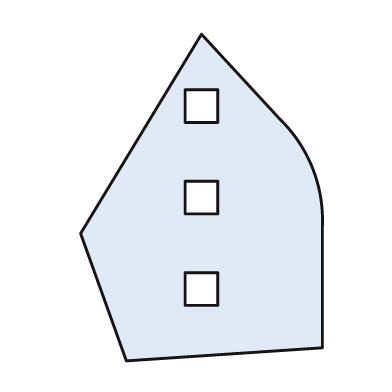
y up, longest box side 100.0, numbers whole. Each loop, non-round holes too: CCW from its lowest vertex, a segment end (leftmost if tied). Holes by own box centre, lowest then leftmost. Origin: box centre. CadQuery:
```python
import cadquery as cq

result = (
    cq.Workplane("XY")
    .moveTo(-23.0, -50.0)
    .lineTo(37.0, -46.0)
    .lineTo(37.0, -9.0)
    .threePointArc((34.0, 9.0), (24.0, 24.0))
    .lineTo(0.0, 50.0)
    .lineTo(-37.0, -11.0)
    .close()
    .moveTo(-5.0, -33.0)
    .lineTo(5.0, -33.0)
    .lineTo(5.0, -23.0)
    .lineTo(-5.0, -23.0)
    .close()
    .moveTo(-5.0, -5.0)
    .lineTo(5.0, -5.0)
    .lineTo(5.0, 5.0)
    .lineTo(-5.0, 5.0)
    .close()
    .moveTo(-5.0, 23.0)
    .lineTo(5.0, 23.0)
    .lineTo(5.0, 33.0)
    .lineTo(-5.0, 33.0)
    .close()
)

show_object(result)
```